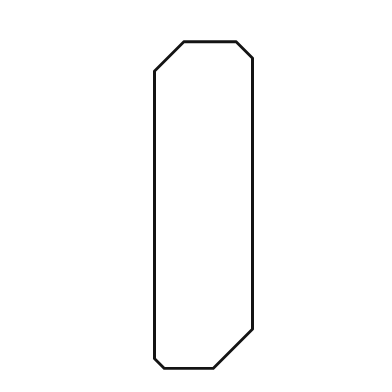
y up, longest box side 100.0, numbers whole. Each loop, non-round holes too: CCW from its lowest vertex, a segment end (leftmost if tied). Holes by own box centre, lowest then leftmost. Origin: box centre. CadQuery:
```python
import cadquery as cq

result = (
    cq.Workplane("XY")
    .moveTo(-12.0, -50.0)
    .lineTo(3.0, -50.0)
    .lineTo(15.0, -38.0)
    .lineTo(15.0, 45.0)
    .lineTo(10.0, 50.0)
    .lineTo(-6.0, 50.0)
    .lineTo(-15.0, 41.0)
    .lineTo(-15.0, -47.0)
    .close()
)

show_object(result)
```